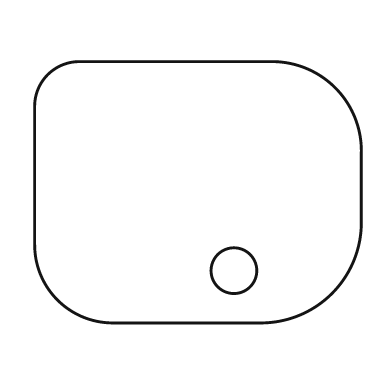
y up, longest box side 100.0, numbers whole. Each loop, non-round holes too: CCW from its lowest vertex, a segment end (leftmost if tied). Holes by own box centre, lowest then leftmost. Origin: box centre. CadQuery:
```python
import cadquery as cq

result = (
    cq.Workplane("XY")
    .moveTo(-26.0, -40.0)
    .lineTo(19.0, -40.0)
    .threePointArc((41.0, -31.0), (50.0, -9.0))
    .lineTo(50.0, 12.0)
    .threePointArc((42.0, 32.0), (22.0, 40.0))
    .lineTo(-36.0, 40.0)
    .threePointArc((-46.0, 36.0), (-50.0, 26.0))
    .lineTo(-50.0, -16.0)
    .threePointArc((-43.0, -33.0), (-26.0, -40.0))
    .close()
    .moveTo(11.0, -24.0)
    .circle(7.0)
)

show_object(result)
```